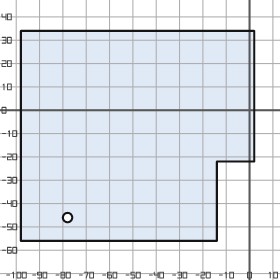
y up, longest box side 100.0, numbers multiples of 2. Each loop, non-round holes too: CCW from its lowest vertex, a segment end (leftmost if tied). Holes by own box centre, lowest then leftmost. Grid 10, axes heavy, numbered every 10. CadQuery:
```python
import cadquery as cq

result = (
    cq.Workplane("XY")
    .moveTo(-98.0, -56.0)
    .lineTo(-14.0, -56.0)
    .lineTo(-14.0, -22.0)
    .lineTo(2.0, -22.0)
    .lineTo(2.0, 34.0)
    .lineTo(-98.0, 34.0)
    .close()
    .moveTo(-78.0, -46.0)
    .circle(2.0)
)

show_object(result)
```